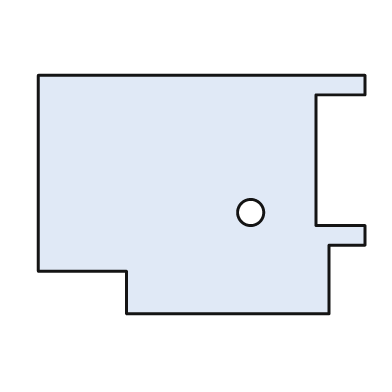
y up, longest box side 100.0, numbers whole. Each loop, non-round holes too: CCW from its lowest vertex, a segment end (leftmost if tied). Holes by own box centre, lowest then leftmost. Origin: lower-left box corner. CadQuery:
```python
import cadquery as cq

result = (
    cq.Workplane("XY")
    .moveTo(27.0, 0.0)
    .lineTo(89.0, 0.0)
    .lineTo(89.0, 21.0)
    .lineTo(100.0, 21.0)
    .lineTo(100.0, 27.0)
    .lineTo(85.0, 27.0)
    .lineTo(85.0, 67.0)
    .lineTo(100.0, 67.0)
    .lineTo(100.0, 73.0)
    .lineTo(0.0, 73.0)
    .lineTo(0.0, 13.0)
    .lineTo(27.0, 13.0)
    .close()
    .moveTo(65.0, 31.0)
    .circle(4.0)
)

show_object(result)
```